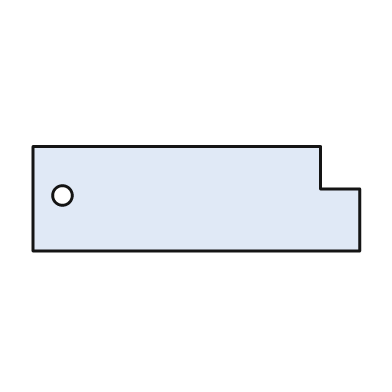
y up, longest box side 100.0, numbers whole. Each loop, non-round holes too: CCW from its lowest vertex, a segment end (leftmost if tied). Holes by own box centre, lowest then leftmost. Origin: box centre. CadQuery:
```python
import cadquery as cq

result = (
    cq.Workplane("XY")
    .moveTo(-50.0, -16.0)
    .lineTo(50.0, -16.0)
    .lineTo(50.0, 3.0)
    .lineTo(38.0, 3.0)
    .lineTo(38.0, 16.0)
    .lineTo(-50.0, 16.0)
    .close()
    .moveTo(-41.0, 1.0)
    .circle(3.0)
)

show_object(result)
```